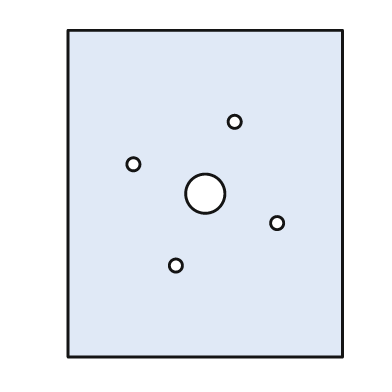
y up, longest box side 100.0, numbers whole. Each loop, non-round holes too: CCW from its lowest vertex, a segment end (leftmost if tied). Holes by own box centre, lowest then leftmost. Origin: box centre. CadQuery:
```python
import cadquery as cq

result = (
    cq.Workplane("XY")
    .moveTo(-42.0, -50.0)
    .lineTo(42.0, -50.0)
    .lineTo(42.0, 50.0)
    .lineTo(-42.0, 50.0)
    .close()
    .moveTo(-9.0, -22.0)
    .circle(2.0)
    .moveTo(22.0, -9.0)
    .circle(2.0)
    .moveTo(0.0, 0.0)
    .circle(6.0)
    .moveTo(-22.0, 9.0)
    .circle(2.0)
    .moveTo(9.0, 22.0)
    .circle(2.0)
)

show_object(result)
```